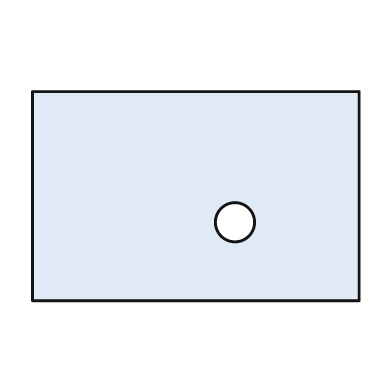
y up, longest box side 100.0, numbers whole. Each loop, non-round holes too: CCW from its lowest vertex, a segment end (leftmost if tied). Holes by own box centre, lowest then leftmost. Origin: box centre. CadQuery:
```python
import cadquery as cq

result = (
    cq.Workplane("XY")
    .moveTo(-50.0, -32.0)
    .lineTo(50.0, -32.0)
    .lineTo(50.0, 32.0)
    .lineTo(-50.0, 32.0)
    .close()
    .moveTo(12.0, -8.0)
    .circle(6.0)
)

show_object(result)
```